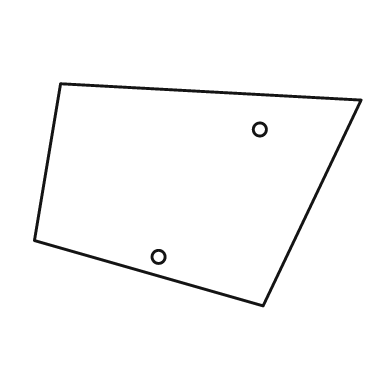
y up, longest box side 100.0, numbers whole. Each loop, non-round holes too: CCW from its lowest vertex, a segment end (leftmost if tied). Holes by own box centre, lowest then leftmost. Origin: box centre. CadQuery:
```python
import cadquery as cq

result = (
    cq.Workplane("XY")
    .moveTo(20.0, -34.0)
    .lineTo(50.0, 29.0)
    .lineTo(-42.0, 34.0)
    .lineTo(-50.0, -14.0)
    .close()
    .moveTo(-12.0, -19.0)
    .circle(2.0)
    .moveTo(19.0, 20.0)
    .circle(2.0)
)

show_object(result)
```